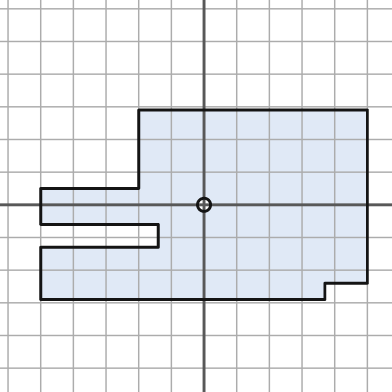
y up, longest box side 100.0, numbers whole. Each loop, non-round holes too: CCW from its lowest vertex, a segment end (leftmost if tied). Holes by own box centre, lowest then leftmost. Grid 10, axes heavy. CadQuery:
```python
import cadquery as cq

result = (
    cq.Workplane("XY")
    .moveTo(-50.0, -29.0)
    .lineTo(37.0, -29.0)
    .lineTo(37.0, -24.0)
    .lineTo(50.0, -24.0)
    .lineTo(50.0, 29.0)
    .lineTo(-20.0, 29.0)
    .lineTo(-20.0, 5.0)
    .lineTo(-50.0, 5.0)
    .lineTo(-50.0, -6.0)
    .lineTo(-14.0, -6.0)
    .lineTo(-14.0, -13.0)
    .lineTo(-50.0, -13.0)
    .close()
    .moveTo(0.0, 0.0)
    .circle(2.0)
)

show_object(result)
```